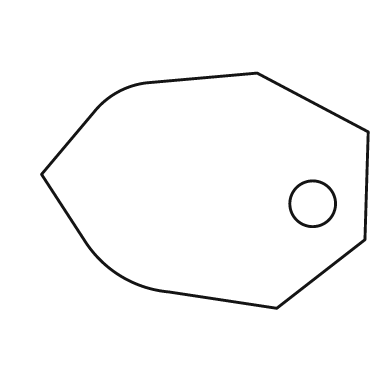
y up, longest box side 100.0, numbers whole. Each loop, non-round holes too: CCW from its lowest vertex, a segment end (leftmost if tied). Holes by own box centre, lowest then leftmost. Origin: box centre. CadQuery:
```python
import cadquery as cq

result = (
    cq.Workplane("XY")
    .moveTo(22.0, -36.0)
    .lineTo(49.0, -15.0)
    .lineTo(50.0, 18.0)
    .lineTo(16.0, 36.0)
    .lineTo(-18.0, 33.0)
    .threePointArc((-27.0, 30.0), (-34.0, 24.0))
    .lineTo(-50.0, 5.0)
    .lineTo(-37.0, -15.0)
    .threePointArc((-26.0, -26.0), (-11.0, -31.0))
    .close()
    .moveTo(33.0, -4.0)
    .circle(7.0)
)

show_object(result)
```